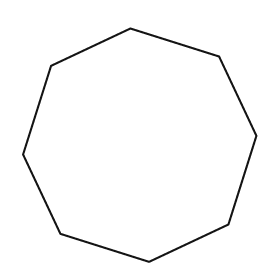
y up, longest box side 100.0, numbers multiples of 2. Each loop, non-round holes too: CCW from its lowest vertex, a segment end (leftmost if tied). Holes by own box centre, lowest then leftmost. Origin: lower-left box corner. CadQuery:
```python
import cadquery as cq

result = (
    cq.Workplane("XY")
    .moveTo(54.0, 0.0)
    .lineTo(88.0, 16.0)
    .lineTo(100.0, 54.0)
    .lineTo(84.0, 88.0)
    .lineTo(46.0, 100.0)
    .lineTo(12.0, 84.0)
    .lineTo(0.0, 46.0)
    .lineTo(16.0, 12.0)
    .close()
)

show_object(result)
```